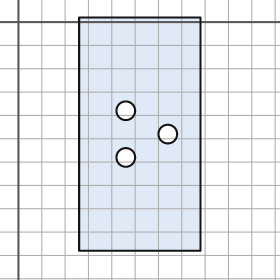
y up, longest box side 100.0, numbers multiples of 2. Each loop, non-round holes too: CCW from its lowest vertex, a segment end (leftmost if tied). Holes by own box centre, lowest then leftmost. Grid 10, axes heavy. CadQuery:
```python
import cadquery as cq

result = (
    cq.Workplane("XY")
    .moveTo(26.0, -98.0)
    .lineTo(78.0, -98.0)
    .lineTo(78.0, 2.0)
    .lineTo(26.0, 2.0)
    .close()
    .moveTo(46.0, -58.0)
    .circle(4.0)
    .moveTo(64.0, -48.0)
    .circle(4.0)
    .moveTo(46.0, -38.0)
    .circle(4.0)
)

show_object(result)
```